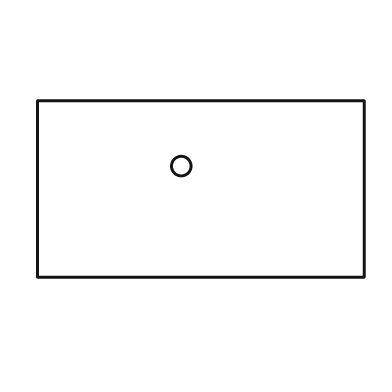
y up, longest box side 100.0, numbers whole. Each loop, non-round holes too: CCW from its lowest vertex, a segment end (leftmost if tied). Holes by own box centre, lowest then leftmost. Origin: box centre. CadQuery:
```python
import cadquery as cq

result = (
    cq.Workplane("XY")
    .moveTo(-50.0, -27.0)
    .lineTo(50.0, -27.0)
    .lineTo(50.0, 27.0)
    .lineTo(-50.0, 27.0)
    .close()
    .moveTo(-6.0, 7.0)
    .circle(3.0)
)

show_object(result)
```